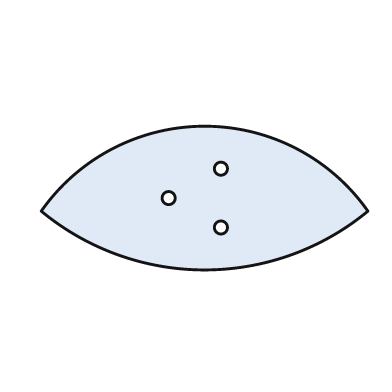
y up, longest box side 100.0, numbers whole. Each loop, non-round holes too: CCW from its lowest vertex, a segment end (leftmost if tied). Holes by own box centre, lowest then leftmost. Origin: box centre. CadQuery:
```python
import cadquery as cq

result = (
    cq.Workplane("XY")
    .moveTo(-50.0, -4.0)
    .threePointArc((0.0, -22.0), (50.0, -4.0))
    .threePointArc((0.0, 22.0), (-50.0, -4.0))
    .close()
    .moveTo(5.0, -9.0)
    .circle(2.0)
    .moveTo(-11.0, 0.0)
    .circle(2.0)
    .moveTo(5.0, 9.0)
    .circle(2.0)
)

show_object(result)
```